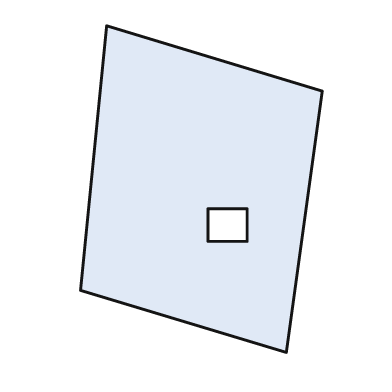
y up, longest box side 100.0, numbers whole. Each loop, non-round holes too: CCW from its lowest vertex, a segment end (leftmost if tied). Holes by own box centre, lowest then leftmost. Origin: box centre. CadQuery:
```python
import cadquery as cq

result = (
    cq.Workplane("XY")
    .moveTo(26.0, -50.0)
    .lineTo(37.0, 30.0)
    .lineTo(-29.0, 50.0)
    .lineTo(-37.0, -31.0)
    .close()
    .moveTo(2.0, -16.0)
    .lineTo(14.0, -16.0)
    .lineTo(14.0, -6.0)
    .lineTo(2.0, -6.0)
    .close()
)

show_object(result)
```